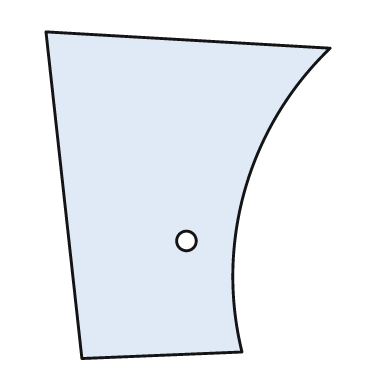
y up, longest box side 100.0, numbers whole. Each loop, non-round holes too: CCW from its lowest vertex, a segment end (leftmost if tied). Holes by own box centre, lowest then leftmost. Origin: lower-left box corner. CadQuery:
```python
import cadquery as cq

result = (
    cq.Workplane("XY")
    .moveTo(11.0, 0.0)
    .lineTo(60.0, 2.0)
    .threePointArc((61.0, 52.0), (87.0, 95.0))
    .lineTo(0.0, 100.0)
    .close()
    .moveTo(43.0, 36.0)
    .circle(3.0)
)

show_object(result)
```